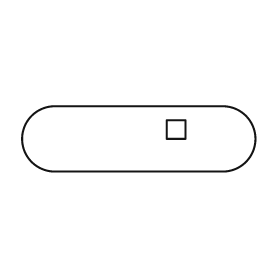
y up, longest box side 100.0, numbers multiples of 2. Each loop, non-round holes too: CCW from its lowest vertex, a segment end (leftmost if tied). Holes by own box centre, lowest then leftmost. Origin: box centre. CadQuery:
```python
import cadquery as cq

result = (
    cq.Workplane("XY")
    .moveTo(-36.0, -14.0)
    .lineTo(36.0, -14.0)
    .threePointArc((50.0, 0.0), (36.0, 14.0))
    .lineTo(-36.0, 14.0)
    .threePointArc((-50.0, 0.0), (-36.0, -14.0))
    .close()
    .moveTo(12.0, 0.0)
    .lineTo(20.0, 0.0)
    .lineTo(20.0, 8.0)
    .lineTo(12.0, 8.0)
    .close()
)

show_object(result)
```